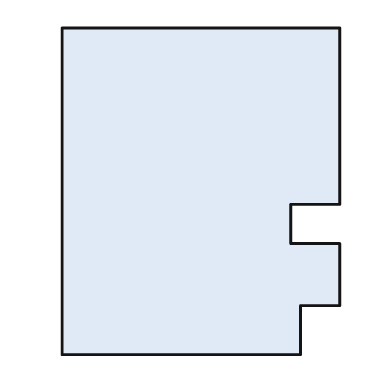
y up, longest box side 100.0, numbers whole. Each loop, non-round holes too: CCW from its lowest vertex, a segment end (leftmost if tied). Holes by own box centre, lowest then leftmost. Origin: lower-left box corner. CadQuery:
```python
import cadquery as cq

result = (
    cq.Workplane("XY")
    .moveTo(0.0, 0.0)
    .lineTo(73.0, 0.0)
    .lineTo(73.0, 15.0)
    .lineTo(85.0, 15.0)
    .lineTo(85.0, 34.0)
    .lineTo(70.0, 34.0)
    .lineTo(70.0, 46.0)
    .lineTo(85.0, 46.0)
    .lineTo(85.0, 100.0)
    .lineTo(0.0, 100.0)
    .close()
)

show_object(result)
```